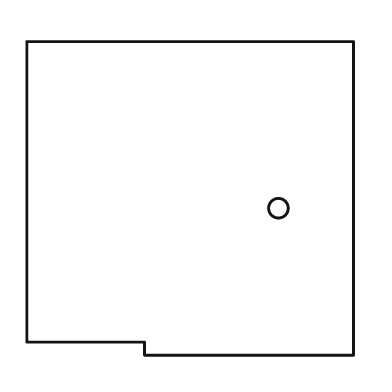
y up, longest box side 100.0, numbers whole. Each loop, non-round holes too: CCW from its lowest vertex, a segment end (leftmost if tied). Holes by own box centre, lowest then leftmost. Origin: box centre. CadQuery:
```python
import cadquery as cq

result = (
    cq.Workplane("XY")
    .moveTo(-14.0, -48.0)
    .lineTo(50.0, -48.0)
    .lineTo(50.0, 48.0)
    .lineTo(-50.0, 48.0)
    .lineTo(-50.0, -44.0)
    .lineTo(-14.0, -44.0)
    .close()
    .moveTo(27.0, -3.0)
    .circle(3.0)
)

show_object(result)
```